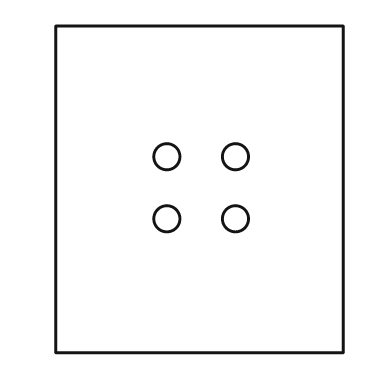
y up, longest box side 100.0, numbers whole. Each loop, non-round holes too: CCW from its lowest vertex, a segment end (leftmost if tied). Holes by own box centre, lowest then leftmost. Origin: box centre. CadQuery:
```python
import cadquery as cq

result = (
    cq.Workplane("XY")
    .moveTo(-44.0, -50.0)
    .lineTo(44.0, -50.0)
    .lineTo(44.0, 50.0)
    .lineTo(-44.0, 50.0)
    .close()
    .moveTo(-10.0, -9.0)
    .circle(4.0)
    .moveTo(11.0, -9.0)
    .circle(4.0)
    .moveTo(-10.0, 10.0)
    .circle(4.0)
    .moveTo(11.0, 10.0)
    .circle(4.0)
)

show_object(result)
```